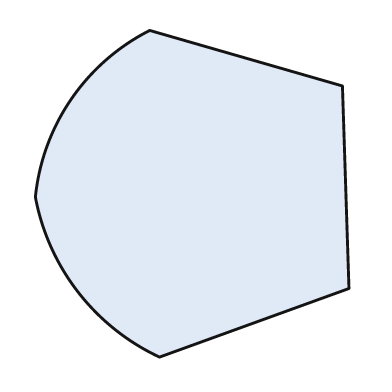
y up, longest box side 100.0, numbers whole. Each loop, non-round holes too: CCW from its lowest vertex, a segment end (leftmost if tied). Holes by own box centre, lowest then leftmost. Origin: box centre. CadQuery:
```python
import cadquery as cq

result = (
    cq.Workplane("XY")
    .moveTo(-10.0, -50.0)
    .lineTo(48.0, -29.0)
    .lineTo(46.0, 33.0)
    .lineTo(-13.0, 50.0)
    .threePointArc((-37.0, 29.0), (-48.0, -1.0))
    .threePointArc((-35.0, -30.0), (-10.0, -50.0))
    .close()
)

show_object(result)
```